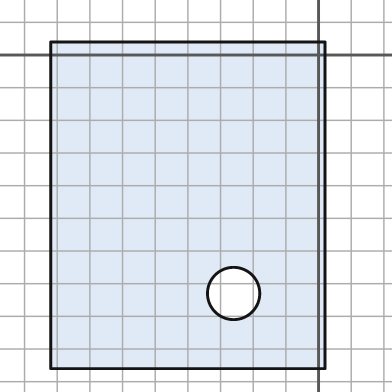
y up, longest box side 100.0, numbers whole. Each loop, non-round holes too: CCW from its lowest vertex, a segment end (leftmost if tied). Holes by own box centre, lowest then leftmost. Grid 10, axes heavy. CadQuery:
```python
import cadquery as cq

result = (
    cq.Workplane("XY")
    .moveTo(-82.0, -96.0)
    .lineTo(2.0, -96.0)
    .lineTo(2.0, 4.0)
    .lineTo(-82.0, 4.0)
    .close()
    .moveTo(-26.0, -73.0)
    .circle(8.0)
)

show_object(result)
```